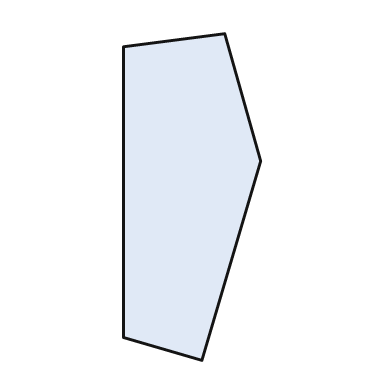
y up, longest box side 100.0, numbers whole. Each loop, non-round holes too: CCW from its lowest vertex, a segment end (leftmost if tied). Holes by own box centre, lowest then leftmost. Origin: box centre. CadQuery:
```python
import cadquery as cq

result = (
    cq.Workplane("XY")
    .moveTo(3.0, -50.0)
    .lineTo(21.0, 11.0)
    .lineTo(10.0, 50.0)
    .lineTo(-21.0, 46.0)
    .lineTo(-21.0, -43.0)
    .close()
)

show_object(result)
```